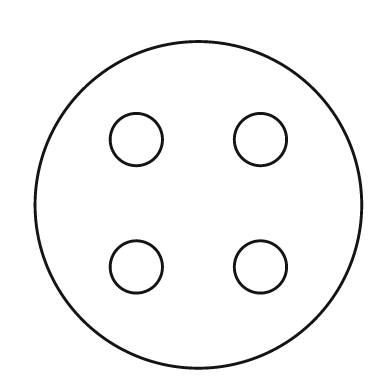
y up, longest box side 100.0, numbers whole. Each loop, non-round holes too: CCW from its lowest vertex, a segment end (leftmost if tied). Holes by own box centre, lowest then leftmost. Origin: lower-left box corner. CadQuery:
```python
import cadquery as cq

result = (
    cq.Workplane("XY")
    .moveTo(50.0, 50.0)
    .circle(50.0)
    .moveTo(31.0, 31.0)
    .circle(8.0)
    .moveTo(69.0, 31.0)
    .circle(8.0)
    .moveTo(31.0, 70.0)
    .circle(8.0)
    .moveTo(69.0, 70.0)
    .circle(8.0)
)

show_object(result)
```